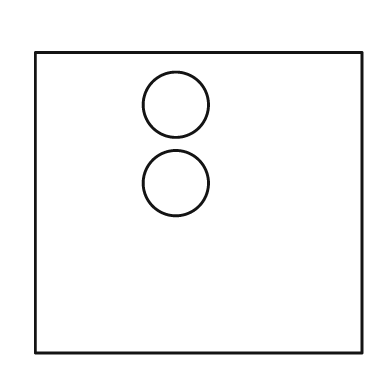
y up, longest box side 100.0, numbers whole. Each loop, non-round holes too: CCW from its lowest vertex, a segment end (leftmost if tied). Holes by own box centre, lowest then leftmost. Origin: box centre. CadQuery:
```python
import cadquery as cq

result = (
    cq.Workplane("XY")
    .moveTo(-50.0, -46.0)
    .lineTo(50.0, -46.0)
    .lineTo(50.0, 46.0)
    .lineTo(-50.0, 46.0)
    .close()
    .moveTo(-7.0, 6.0)
    .circle(10.0)
    .moveTo(-7.0, 30.0)
    .circle(10.0)
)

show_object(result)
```